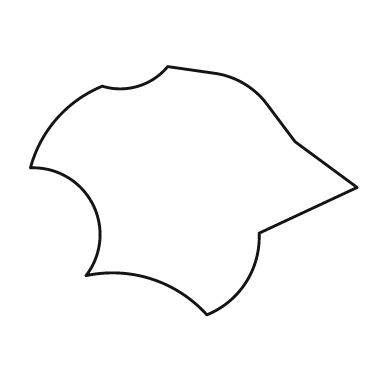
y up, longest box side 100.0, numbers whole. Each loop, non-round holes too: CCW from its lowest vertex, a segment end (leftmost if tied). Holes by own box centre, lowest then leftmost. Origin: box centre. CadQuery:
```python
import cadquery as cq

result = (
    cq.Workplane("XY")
    .moveTo(4.0, -38.0)
    .threePointArc((16.0, -28.0), (20.0, -13.0))
    .lineTo(50.0, 1.0)
    .lineTo(31.0, 15.0)
    .lineTo(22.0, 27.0)
    .threePointArc((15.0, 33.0), (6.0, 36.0))
    .lineTo(-8.0, 38.0)
    .threePointArc((-17.0, 32.0), (-28.0, 32.0))
    .threePointArc((-42.0, 22.0), (-50.0, 7.0))
    .threePointArc((-31.0, -4.0), (-33.0, -26.0))
    .threePointArc((-13.0, -27.0), (4.0, -38.0))
    .close()
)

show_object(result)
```